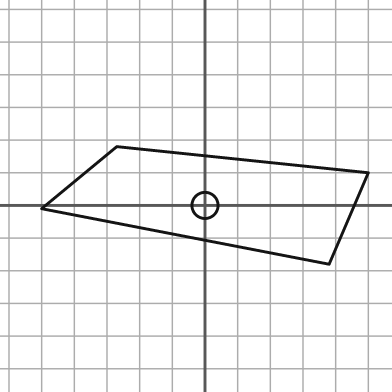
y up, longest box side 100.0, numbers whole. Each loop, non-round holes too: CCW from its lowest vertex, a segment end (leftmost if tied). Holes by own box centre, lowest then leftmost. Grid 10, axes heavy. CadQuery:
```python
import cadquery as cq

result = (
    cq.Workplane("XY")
    .moveTo(38.0, -18.0)
    .lineTo(50.0, 10.0)
    .lineTo(-27.0, 18.0)
    .lineTo(-50.0, -1.0)
    .close()
    .moveTo(0.0, 0.0)
    .circle(4.0)
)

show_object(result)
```